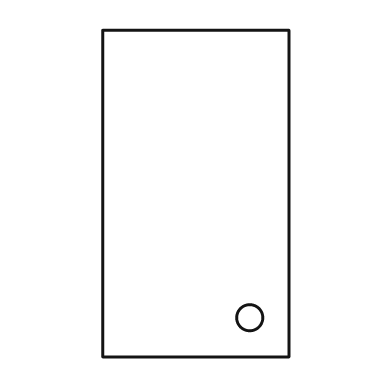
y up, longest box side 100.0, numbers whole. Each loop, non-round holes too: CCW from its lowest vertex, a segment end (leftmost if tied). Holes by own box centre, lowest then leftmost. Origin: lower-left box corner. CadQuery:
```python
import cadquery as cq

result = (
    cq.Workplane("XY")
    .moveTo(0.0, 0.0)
    .lineTo(57.0, 0.0)
    .lineTo(57.0, 100.0)
    .lineTo(0.0, 100.0)
    .close()
    .moveTo(45.0, 12.0)
    .circle(4.0)
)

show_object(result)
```